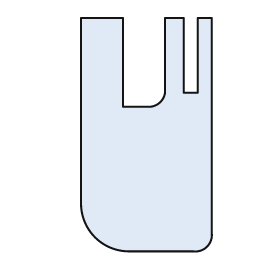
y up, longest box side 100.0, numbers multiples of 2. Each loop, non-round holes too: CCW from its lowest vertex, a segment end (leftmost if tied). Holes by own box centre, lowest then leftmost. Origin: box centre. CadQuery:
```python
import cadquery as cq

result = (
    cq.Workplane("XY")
    .moveTo(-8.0, -50.0)
    .lineTo(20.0, -50.0)
    .threePointArc((26.0, -48.0), (28.0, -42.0))
    .lineTo(28.0, 50.0)
    .lineTo(22.0, 50.0)
    .lineTo(22.0, 18.0)
    .lineTo(16.0, 18.0)
    .lineTo(16.0, 50.0)
    .lineTo(8.0, 50.0)
    .lineTo(8.0, 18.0)
    .threePointArc((6.0, 14.0), (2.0, 12.0))
    .lineTo(-10.0, 12.0)
    .lineTo(-10.0, 50.0)
    .lineTo(-28.0, 50.0)
    .lineTo(-28.0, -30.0)
    .threePointArc((-22.0, -44.0), (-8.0, -50.0))
    .close()
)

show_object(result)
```